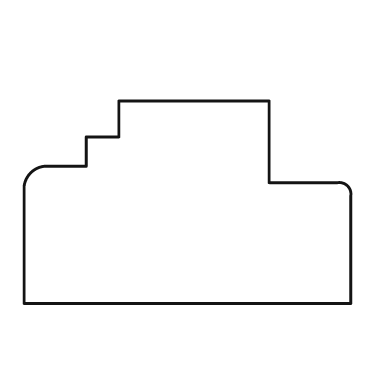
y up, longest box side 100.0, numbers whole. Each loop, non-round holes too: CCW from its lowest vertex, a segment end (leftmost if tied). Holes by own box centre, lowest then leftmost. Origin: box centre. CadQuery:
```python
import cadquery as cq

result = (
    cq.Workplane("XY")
    .moveTo(-50.0, -31.0)
    .lineTo(50.0, -31.0)
    .lineTo(50.0, 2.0)
    .threePointArc((49.0, 5.0), (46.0, 6.0))
    .lineTo(25.0, 6.0)
    .lineTo(25.0, 31.0)
    .lineTo(-21.0, 31.0)
    .lineTo(-21.0, 20.0)
    .lineTo(-31.0, 20.0)
    .lineTo(-31.0, 11.0)
    .lineTo(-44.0, 11.0)
    .threePointArc((-48.0, 9.0), (-50.0, 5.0))
    .close()
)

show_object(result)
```